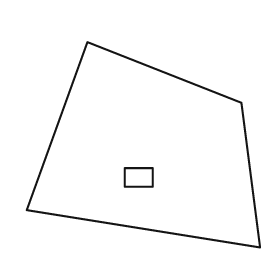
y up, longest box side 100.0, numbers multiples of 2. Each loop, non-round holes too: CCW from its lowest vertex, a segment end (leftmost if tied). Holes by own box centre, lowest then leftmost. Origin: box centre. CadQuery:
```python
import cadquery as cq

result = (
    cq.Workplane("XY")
    .moveTo(50.0, -44.0)
    .lineTo(42.0, 18.0)
    .lineTo(-24.0, 44.0)
    .lineTo(-50.0, -28.0)
    .close()
    .moveTo(-8.0, -18.0)
    .lineTo(4.0, -18.0)
    .lineTo(4.0, -10.0)
    .lineTo(-8.0, -10.0)
    .close()
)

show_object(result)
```